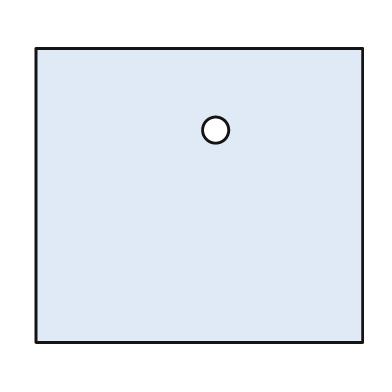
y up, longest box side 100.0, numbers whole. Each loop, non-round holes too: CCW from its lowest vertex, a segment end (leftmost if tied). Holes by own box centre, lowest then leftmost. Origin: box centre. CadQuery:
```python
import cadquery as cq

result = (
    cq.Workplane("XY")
    .moveTo(-50.0, -45.0)
    .lineTo(50.0, -45.0)
    .lineTo(50.0, 45.0)
    .lineTo(-50.0, 45.0)
    .close()
    .moveTo(5.0, 20.0)
    .circle(4.0)
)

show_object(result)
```